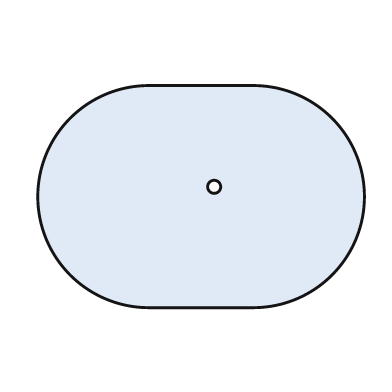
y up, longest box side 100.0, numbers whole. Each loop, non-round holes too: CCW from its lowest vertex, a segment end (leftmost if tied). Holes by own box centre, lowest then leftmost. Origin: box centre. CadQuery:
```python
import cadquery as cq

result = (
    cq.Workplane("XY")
    .moveTo(-16.0, -34.0)
    .lineTo(16.0, -34.0)
    .threePointArc((50.0, 0.0), (16.0, 34.0))
    .lineTo(-16.0, 34.0)
    .threePointArc((-50.0, 0.0), (-16.0, -34.0))
    .close()
    .moveTo(4.0, 3.0)
    .circle(2.0)
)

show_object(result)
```